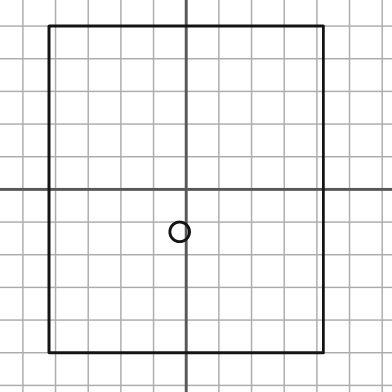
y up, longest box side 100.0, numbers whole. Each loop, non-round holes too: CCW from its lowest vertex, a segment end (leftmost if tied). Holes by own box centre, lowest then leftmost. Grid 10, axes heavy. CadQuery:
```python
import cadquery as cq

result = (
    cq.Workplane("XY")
    .moveTo(-42.0, -50.0)
    .lineTo(42.0, -50.0)
    .lineTo(42.0, 50.0)
    .lineTo(-42.0, 50.0)
    .close()
    .moveTo(-2.0, -13.0)
    .circle(3.0)
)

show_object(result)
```